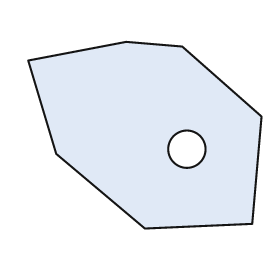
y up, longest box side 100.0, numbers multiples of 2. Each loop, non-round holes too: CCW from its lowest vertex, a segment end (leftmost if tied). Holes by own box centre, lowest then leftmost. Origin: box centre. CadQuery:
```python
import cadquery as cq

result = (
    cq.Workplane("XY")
    .moveTo(0.0, -40.0)
    .lineTo(46.0, -38.0)
    .lineTo(50.0, 8.0)
    .lineTo(16.0, 38.0)
    .lineTo(-8.0, 40.0)
    .lineTo(-50.0, 32.0)
    .lineTo(-38.0, -8.0)
    .close()
    .moveTo(18.0, -6.0)
    .circle(8.0)
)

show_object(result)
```